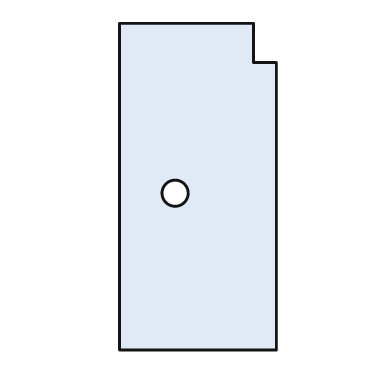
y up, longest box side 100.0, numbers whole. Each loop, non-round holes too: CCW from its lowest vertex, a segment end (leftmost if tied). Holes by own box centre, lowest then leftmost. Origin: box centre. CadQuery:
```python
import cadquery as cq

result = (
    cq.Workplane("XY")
    .moveTo(-24.0, -50.0)
    .lineTo(24.0, -50.0)
    .lineTo(24.0, 38.0)
    .lineTo(17.0, 38.0)
    .lineTo(17.0, 50.0)
    .lineTo(-24.0, 50.0)
    .close()
    .moveTo(-7.0, -2.0)
    .circle(4.0)
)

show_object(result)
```